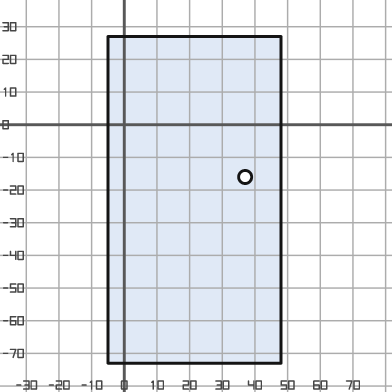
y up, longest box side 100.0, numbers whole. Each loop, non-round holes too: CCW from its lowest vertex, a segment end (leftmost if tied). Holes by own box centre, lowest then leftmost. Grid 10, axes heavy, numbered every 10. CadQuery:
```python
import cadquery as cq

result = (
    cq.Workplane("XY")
    .moveTo(-5.0, -73.0)
    .lineTo(48.0, -73.0)
    .lineTo(48.0, 27.0)
    .lineTo(-5.0, 27.0)
    .close()
    .moveTo(37.0, -16.0)
    .circle(2.0)
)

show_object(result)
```